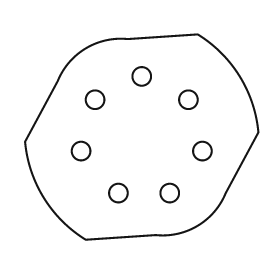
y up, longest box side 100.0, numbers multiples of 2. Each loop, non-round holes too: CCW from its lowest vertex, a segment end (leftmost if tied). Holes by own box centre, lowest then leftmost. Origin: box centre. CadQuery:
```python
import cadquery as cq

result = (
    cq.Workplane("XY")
    .moveTo(-24.0, -44.0)
    .lineTo(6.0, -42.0)
    .threePointArc((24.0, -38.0), (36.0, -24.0))
    .lineTo(50.0, 2.0)
    .threePointArc((42.0, 26.0), (24.0, 44.0))
    .lineTo(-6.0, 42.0)
    .threePointArc((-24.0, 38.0), (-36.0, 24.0))
    .lineTo(-50.0, -2.0)
    .threePointArc((-42.0, -26.0), (-24.0, -44.0))
    .close()
    .moveTo(-10.0, -24.0)
    .circle(4.0)
    .moveTo(12.0, -24.0)
    .circle(4.0)
    .moveTo(-26.0, -6.0)
    .circle(4.0)
    .moveTo(26.0, -6.0)
    .circle(4.0)
    .moveTo(-20.0, 16.0)
    .circle(4.0)
    .moveTo(20.0, 16.0)
    .circle(4.0)
    .moveTo(0.0, 26.0)
    .circle(4.0)
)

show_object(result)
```